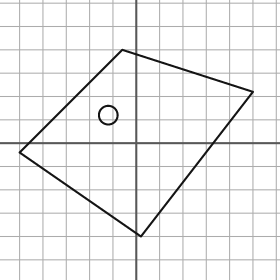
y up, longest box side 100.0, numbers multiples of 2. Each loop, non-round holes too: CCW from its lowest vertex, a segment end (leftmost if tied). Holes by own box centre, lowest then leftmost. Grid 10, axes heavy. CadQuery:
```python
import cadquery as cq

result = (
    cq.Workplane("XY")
    .moveTo(2.0, -40.0)
    .lineTo(50.0, 22.0)
    .lineTo(-6.0, 40.0)
    .lineTo(-50.0, -4.0)
    .close()
    .moveTo(-12.0, 12.0)
    .circle(4.0)
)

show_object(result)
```